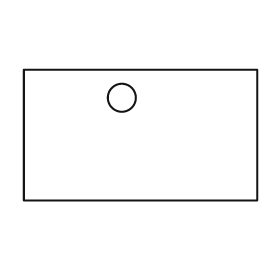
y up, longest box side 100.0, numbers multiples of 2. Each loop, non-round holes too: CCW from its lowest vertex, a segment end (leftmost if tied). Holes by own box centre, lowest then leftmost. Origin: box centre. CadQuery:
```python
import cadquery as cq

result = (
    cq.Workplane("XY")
    .moveTo(-50.0, -28.0)
    .lineTo(50.0, -28.0)
    .lineTo(50.0, 28.0)
    .lineTo(-50.0, 28.0)
    .close()
    .moveTo(-8.0, 16.0)
    .circle(6.0)
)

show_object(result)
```